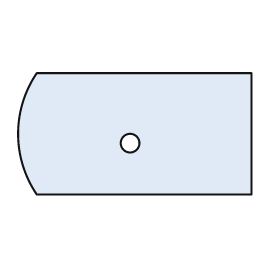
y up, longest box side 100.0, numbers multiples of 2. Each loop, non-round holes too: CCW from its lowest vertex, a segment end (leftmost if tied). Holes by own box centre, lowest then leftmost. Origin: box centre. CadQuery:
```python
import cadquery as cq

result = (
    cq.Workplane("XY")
    .moveTo(-42.0, -26.0)
    .lineTo(50.0, -26.0)
    .lineTo(50.0, 26.0)
    .lineTo(-42.0, 26.0)
    .threePointArc((-50.0, 0.0), (-42.0, -26.0))
    .close()
    .moveTo(-2.0, -4.0)
    .circle(4.0)
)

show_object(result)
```